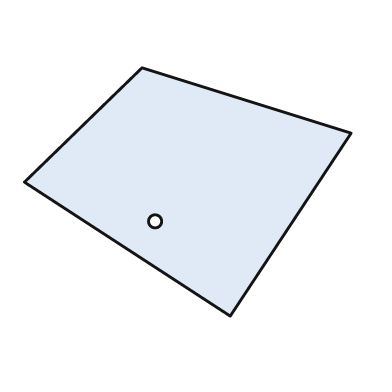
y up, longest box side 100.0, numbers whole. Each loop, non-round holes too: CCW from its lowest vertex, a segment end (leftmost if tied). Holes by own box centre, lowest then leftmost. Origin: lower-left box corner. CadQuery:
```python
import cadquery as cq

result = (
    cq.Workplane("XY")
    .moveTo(63.0, 0.0)
    .lineTo(100.0, 56.0)
    .lineTo(36.0, 76.0)
    .lineTo(0.0, 41.0)
    .close()
    .moveTo(40.0, 29.0)
    .circle(2.0)
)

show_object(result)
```